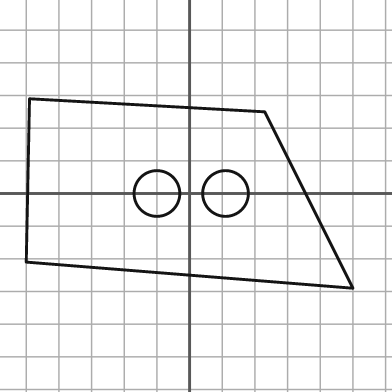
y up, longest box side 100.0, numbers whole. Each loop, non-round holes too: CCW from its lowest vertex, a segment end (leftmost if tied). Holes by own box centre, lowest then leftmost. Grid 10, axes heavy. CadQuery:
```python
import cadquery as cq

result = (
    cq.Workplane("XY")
    .moveTo(50.0, -29.0)
    .lineTo(23.0, 25.0)
    .lineTo(-49.0, 29.0)
    .lineTo(-50.0, -21.0)
    .close()
    .moveTo(-10.0, 0.0)
    .circle(7.0)
    .moveTo(11.0, 0.0)
    .circle(7.0)
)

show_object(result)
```